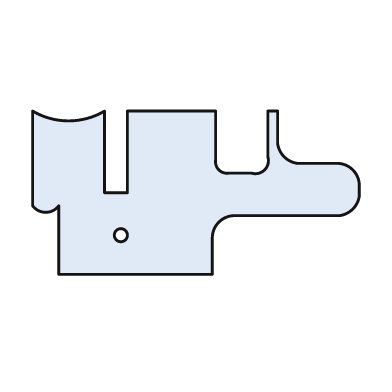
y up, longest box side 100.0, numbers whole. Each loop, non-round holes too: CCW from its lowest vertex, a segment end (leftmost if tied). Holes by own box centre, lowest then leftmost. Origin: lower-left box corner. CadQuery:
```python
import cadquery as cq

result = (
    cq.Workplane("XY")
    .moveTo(8.0, 0.0)
    .lineTo(55.0, 0.0)
    .lineTo(55.0, 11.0)
    .threePointArc((57.0, 16.0), (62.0, 18.0))
    .lineTo(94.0, 18.0)
    .threePointArc((98.0, 20.0), (100.0, 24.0))
    .lineTo(100.0, 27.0)
    .threePointArc((98.0, 32.0), (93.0, 34.0))
    .lineTo(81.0, 34.0)
    .threePointArc((77.0, 36.0), (75.0, 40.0))
    .lineTo(75.0, 50.0)
    .lineTo(72.0, 50.0)
    .lineTo(72.0, 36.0)
    .threePointArc((71.0, 32.0), (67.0, 31.0))
    .lineTo(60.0, 31.0)
    .threePointArc((57.0, 32.0), (56.0, 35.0))
    .lineTo(56.0, 50.0)
    .lineTo(29.0, 50.0)
    .lineTo(29.0, 25.0)
    .lineTo(22.0, 25.0)
    .lineTo(22.0, 50.0)
    .threePointArc((11.0, 47.0), (0.0, 50.0))
    .lineTo(0.0, 21.0)
    .threePointArc((4.0, 19.0), (8.0, 21.0))
    .close()
    .moveTo(27.0, 12.0)
    .circle(2.0)
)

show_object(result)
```